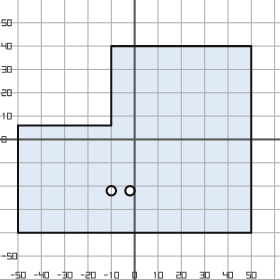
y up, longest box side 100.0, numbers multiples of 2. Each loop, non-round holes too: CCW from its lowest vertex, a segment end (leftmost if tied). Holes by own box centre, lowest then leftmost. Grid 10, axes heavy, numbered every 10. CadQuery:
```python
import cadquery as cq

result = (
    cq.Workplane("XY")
    .moveTo(-50.0, -40.0)
    .lineTo(50.0, -40.0)
    .lineTo(50.0, 40.0)
    .lineTo(-10.0, 40.0)
    .lineTo(-10.0, 6.0)
    .lineTo(-50.0, 6.0)
    .close()
    .moveTo(-10.0, -22.0)
    .circle(2.0)
    .moveTo(-2.0, -22.0)
    .circle(2.0)
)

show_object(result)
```